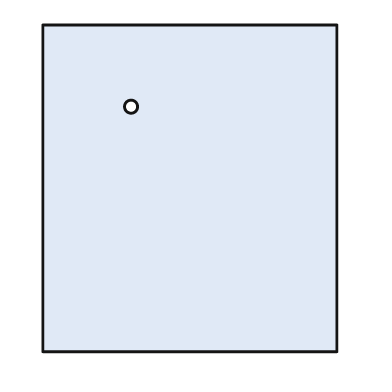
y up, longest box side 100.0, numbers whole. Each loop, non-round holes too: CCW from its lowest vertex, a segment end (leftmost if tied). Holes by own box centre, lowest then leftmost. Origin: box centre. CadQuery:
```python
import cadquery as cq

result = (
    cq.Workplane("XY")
    .moveTo(-45.0, -50.0)
    .lineTo(45.0, -50.0)
    .lineTo(45.0, 50.0)
    .lineTo(-45.0, 50.0)
    .close()
    .moveTo(-18.0, 25.0)
    .circle(2.0)
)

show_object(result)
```